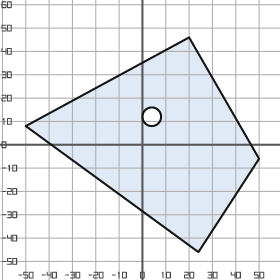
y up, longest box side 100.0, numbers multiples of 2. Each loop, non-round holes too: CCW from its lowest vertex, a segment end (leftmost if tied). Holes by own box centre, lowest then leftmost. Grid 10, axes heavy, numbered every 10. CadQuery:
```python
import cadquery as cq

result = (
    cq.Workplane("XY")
    .moveTo(24.0, -46.0)
    .lineTo(50.0, -6.0)
    .lineTo(20.0, 46.0)
    .lineTo(-50.0, 8.0)
    .close()
    .moveTo(4.0, 12.0)
    .circle(4.0)
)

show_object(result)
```